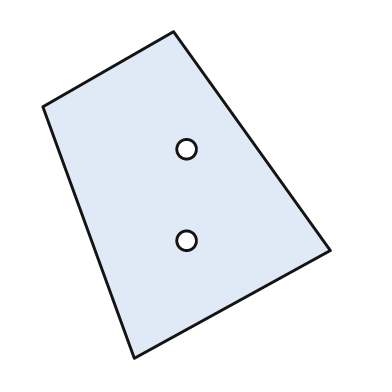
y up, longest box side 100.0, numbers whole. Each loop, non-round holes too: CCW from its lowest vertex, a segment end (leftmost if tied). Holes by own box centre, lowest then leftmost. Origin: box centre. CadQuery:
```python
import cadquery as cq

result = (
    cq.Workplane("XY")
    .moveTo(-16.0, -50.0)
    .lineTo(44.0, -17.0)
    .lineTo(-4.0, 50.0)
    .lineTo(-44.0, 27.0)
    .close()
    .moveTo(0.0, -14.0)
    .circle(3.0)
    .moveTo(0.0, 14.0)
    .circle(3.0)
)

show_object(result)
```